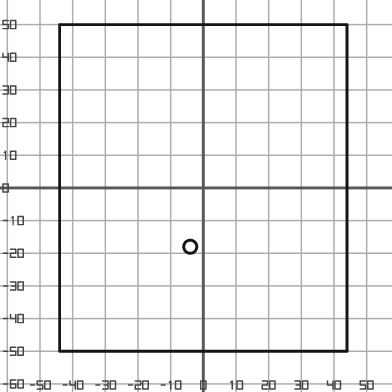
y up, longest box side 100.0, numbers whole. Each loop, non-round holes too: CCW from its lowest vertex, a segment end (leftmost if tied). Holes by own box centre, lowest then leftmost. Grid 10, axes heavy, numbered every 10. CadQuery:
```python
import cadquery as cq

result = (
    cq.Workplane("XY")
    .moveTo(-44.0, -50.0)
    .lineTo(44.0, -50.0)
    .lineTo(44.0, 50.0)
    .lineTo(-44.0, 50.0)
    .close()
    .moveTo(-4.0, -18.0)
    .circle(2.0)
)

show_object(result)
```